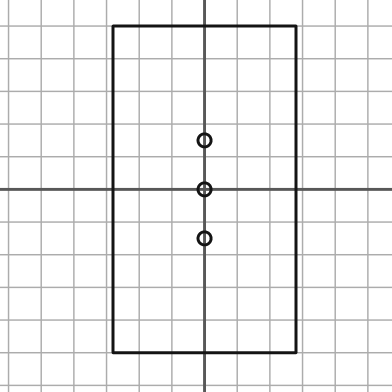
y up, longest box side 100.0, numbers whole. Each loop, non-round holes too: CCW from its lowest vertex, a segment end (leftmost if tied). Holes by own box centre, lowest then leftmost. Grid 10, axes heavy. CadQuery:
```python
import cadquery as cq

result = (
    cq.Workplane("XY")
    .moveTo(-28.0, -50.0)
    .lineTo(28.0, -50.0)
    .lineTo(28.0, 50.0)
    .lineTo(-28.0, 50.0)
    .close()
    .moveTo(0.0, -15.0)
    .circle(2.0)
    .moveTo(0.0, 0.0)
    .circle(2.0)
    .moveTo(0.0, 15.0)
    .circle(2.0)
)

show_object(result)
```